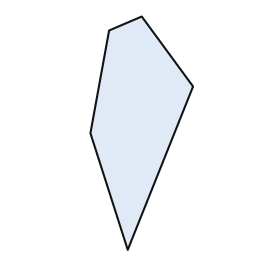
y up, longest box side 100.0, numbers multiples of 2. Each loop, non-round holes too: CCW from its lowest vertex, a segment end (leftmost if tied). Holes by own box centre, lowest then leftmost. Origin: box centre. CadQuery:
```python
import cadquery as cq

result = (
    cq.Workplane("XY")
    .moveTo(-6.0, -50.0)
    .lineTo(22.0, 20.0)
    .lineTo(0.0, 50.0)
    .lineTo(-14.0, 44.0)
    .lineTo(-22.0, 0.0)
    .close()
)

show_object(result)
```